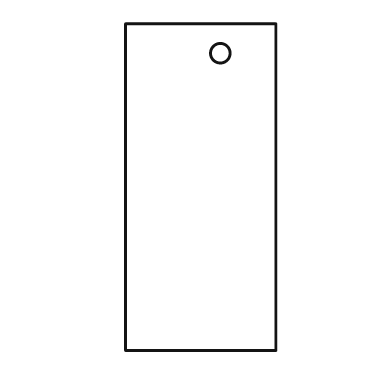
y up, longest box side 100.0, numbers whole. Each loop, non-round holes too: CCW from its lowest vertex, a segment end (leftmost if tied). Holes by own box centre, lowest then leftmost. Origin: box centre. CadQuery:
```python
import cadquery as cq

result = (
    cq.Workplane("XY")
    .moveTo(-23.0, -50.0)
    .lineTo(23.0, -50.0)
    .lineTo(23.0, 50.0)
    .lineTo(-23.0, 50.0)
    .close()
    .moveTo(6.0, 41.0)
    .circle(3.0)
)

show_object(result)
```